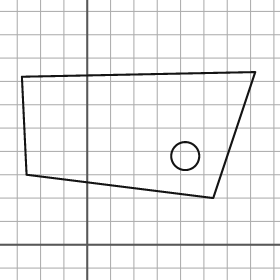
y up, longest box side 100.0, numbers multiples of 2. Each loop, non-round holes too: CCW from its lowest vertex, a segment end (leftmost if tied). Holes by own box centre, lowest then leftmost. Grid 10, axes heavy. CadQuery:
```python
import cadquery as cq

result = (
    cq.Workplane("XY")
    .moveTo(54.0, 20.0)
    .lineTo(72.0, 74.0)
    .lineTo(-28.0, 72.0)
    .lineTo(-26.0, 30.0)
    .close()
    .moveTo(42.0, 38.0)
    .circle(6.0)
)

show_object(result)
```